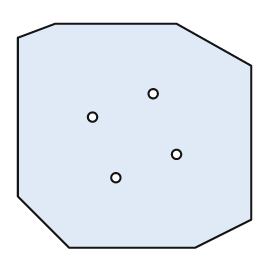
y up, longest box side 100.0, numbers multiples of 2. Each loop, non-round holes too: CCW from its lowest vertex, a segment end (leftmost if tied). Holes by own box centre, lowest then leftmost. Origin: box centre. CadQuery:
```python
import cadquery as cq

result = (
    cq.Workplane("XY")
    .moveTo(-28.0, -48.0)
    .lineTo(26.0, -48.0)
    .lineTo(50.0, -36.0)
    .lineTo(50.0, 30.0)
    .lineTo(18.0, 48.0)
    .lineTo(-34.0, 48.0)
    .lineTo(-50.0, 42.0)
    .lineTo(-50.0, -26.0)
    .close()
    .moveTo(-8.0, -18.0)
    .circle(2.0)
    .moveTo(18.0, -8.0)
    .circle(2.0)
    .moveTo(-18.0, 8.0)
    .circle(2.0)
    .moveTo(8.0, 18.0)
    .circle(2.0)
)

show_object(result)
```